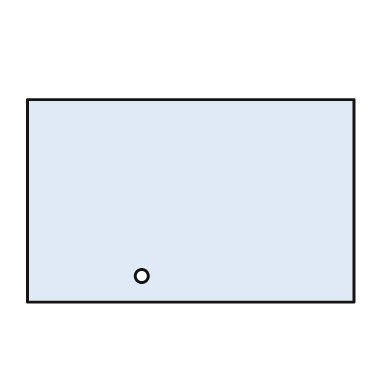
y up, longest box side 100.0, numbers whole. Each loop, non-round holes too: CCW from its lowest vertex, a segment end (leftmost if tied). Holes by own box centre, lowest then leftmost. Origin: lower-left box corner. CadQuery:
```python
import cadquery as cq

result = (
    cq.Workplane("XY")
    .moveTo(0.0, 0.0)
    .lineTo(100.0, 0.0)
    .lineTo(100.0, 62.0)
    .lineTo(0.0, 62.0)
    .close()
    .moveTo(35.0, 8.0)
    .circle(2.0)
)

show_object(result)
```